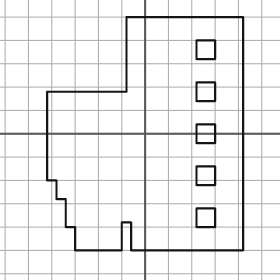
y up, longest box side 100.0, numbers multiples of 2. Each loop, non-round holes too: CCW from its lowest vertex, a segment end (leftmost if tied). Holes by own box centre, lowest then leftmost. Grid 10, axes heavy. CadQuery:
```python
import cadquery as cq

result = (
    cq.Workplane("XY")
    .moveTo(-30.0, -50.0)
    .lineTo(-10.0, -50.0)
    .lineTo(-10.0, -38.0)
    .lineTo(-6.0, -38.0)
    .lineTo(-6.0, -50.0)
    .lineTo(42.0, -50.0)
    .lineTo(42.0, 50.0)
    .lineTo(-8.0, 50.0)
    .lineTo(-8.0, 18.0)
    .lineTo(-42.0, 18.0)
    .lineTo(-42.0, -20.0)
    .lineTo(-38.0, -20.0)
    .lineTo(-38.0, -28.0)
    .lineTo(-34.0, -28.0)
    .lineTo(-34.0, -40.0)
    .lineTo(-30.0, -40.0)
    .close()
    .moveTo(22.0, -40.0)
    .lineTo(30.0, -40.0)
    .lineTo(30.0, -32.0)
    .lineTo(22.0, -32.0)
    .close()
    .moveTo(22.0, -22.0)
    .lineTo(30.0, -22.0)
    .lineTo(30.0, -14.0)
    .lineTo(22.0, -14.0)
    .close()
    .moveTo(22.0, -4.0)
    .lineTo(30.0, -4.0)
    .lineTo(30.0, 4.0)
    .lineTo(22.0, 4.0)
    .close()
    .moveTo(22.0, 14.0)
    .lineTo(30.0, 14.0)
    .lineTo(30.0, 22.0)
    .lineTo(22.0, 22.0)
    .close()
    .moveTo(22.0, 32.0)
    .lineTo(30.0, 32.0)
    .lineTo(30.0, 40.0)
    .lineTo(22.0, 40.0)
    .close()
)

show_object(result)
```